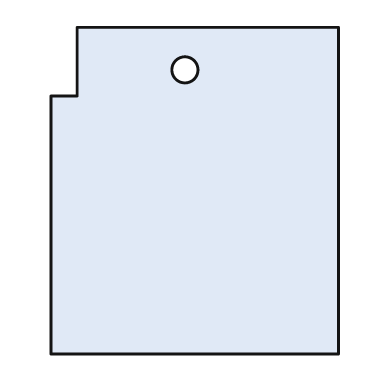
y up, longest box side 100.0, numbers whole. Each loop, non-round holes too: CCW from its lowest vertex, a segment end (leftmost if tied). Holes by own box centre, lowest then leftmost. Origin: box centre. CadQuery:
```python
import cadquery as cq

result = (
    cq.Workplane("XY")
    .moveTo(-44.0, -50.0)
    .lineTo(44.0, -50.0)
    .lineTo(44.0, 50.0)
    .lineTo(-36.0, 50.0)
    .lineTo(-36.0, 29.0)
    .lineTo(-44.0, 29.0)
    .close()
    .moveTo(-3.0, 37.0)
    .circle(4.0)
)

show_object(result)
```